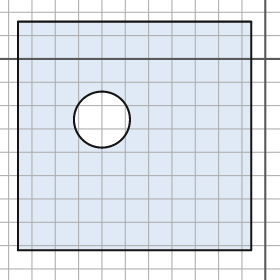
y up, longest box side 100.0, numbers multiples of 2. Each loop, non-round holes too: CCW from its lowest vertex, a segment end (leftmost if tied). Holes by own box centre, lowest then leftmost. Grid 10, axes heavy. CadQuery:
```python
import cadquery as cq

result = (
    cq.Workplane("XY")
    .moveTo(-106.0, -82.0)
    .lineTo(-6.0, -82.0)
    .lineTo(-6.0, 16.0)
    .lineTo(-106.0, 16.0)
    .close()
    .moveTo(-70.0, -26.0)
    .circle(12.0)
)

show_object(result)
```